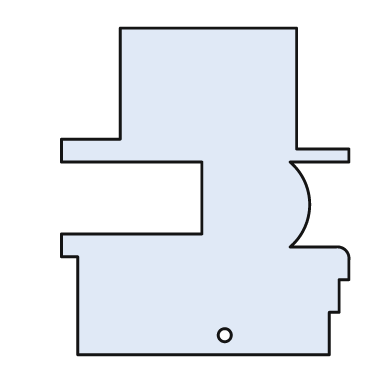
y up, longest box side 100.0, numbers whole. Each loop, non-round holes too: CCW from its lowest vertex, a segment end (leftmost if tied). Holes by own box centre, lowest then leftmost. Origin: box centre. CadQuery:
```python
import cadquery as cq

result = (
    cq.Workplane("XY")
    .moveTo(-39.0, -50.0)
    .lineTo(38.0, -50.0)
    .lineTo(38.0, -37.0)
    .lineTo(41.0, -37.0)
    .lineTo(41.0, -27.0)
    .lineTo(44.0, -27.0)
    .lineTo(44.0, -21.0)
    .threePointArc((43.0, -18.0), (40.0, -17.0))
    .lineTo(26.0, -17.0)
    .threePointArc((32.0, -4.0), (26.0, 9.0))
    .lineTo(44.0, 9.0)
    .lineTo(44.0, 13.0)
    .lineTo(28.0, 13.0)
    .lineTo(28.0, 50.0)
    .lineTo(-26.0, 50.0)
    .lineTo(-26.0, 16.0)
    .lineTo(-44.0, 16.0)
    .lineTo(-44.0, 9.0)
    .lineTo(-1.0, 9.0)
    .lineTo(-1.0, -13.0)
    .lineTo(-44.0, -13.0)
    .lineTo(-44.0, -20.0)
    .lineTo(-39.0, -20.0)
    .close()
    .moveTo(6.0, -44.0)
    .circle(2.0)
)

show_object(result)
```